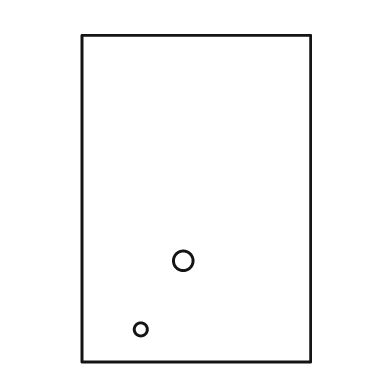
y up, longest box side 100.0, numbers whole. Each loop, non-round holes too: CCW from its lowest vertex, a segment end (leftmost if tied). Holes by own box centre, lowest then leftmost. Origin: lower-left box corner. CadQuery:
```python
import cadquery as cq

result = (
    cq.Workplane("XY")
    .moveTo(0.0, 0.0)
    .lineTo(70.0, 0.0)
    .lineTo(70.0, 100.0)
    .lineTo(0.0, 100.0)
    .close()
    .moveTo(18.0, 10.0)
    .circle(2.0)
    .moveTo(31.0, 31.0)
    .circle(3.0)
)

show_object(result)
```